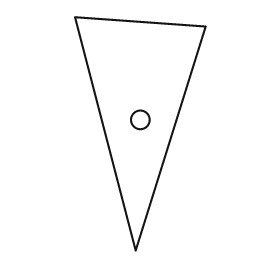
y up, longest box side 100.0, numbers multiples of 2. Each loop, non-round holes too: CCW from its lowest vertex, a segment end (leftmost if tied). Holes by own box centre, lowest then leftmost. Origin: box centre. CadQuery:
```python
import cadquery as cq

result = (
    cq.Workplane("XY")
    .moveTo(-2.0, -50.0)
    .lineTo(28.0, 46.0)
    .lineTo(-28.0, 50.0)
    .close()
    .moveTo(0.0, 6.0)
    .circle(4.0)
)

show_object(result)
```